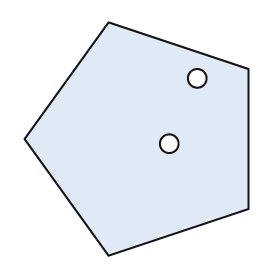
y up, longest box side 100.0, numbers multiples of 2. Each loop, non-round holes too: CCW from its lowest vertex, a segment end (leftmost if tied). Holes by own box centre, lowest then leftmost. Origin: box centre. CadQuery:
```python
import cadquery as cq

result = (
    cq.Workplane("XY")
    .moveTo(-12.0, -50.0)
    .lineTo(48.0, -30.0)
    .lineTo(48.0, 30.0)
    .lineTo(-12.0, 50.0)
    .lineTo(-48.0, 0.0)
    .close()
    .moveTo(14.0, -2.0)
    .circle(4.0)
    .moveTo(26.0, 26.0)
    .circle(4.0)
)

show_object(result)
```